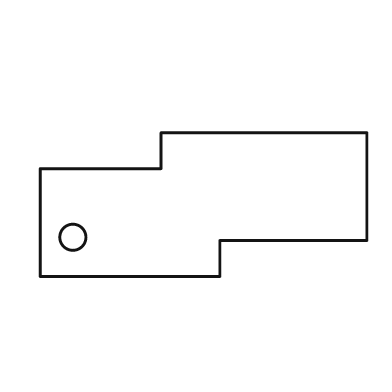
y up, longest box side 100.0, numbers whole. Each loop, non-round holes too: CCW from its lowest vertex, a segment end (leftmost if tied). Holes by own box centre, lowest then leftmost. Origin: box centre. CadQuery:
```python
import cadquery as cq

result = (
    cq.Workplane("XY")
    .moveTo(-50.0, -22.0)
    .lineTo(5.0, -22.0)
    .lineTo(5.0, -11.0)
    .lineTo(50.0, -11.0)
    .lineTo(50.0, 22.0)
    .lineTo(-13.0, 22.0)
    .lineTo(-13.0, 11.0)
    .lineTo(-50.0, 11.0)
    .close()
    .moveTo(-40.0, -10.0)
    .circle(4.0)
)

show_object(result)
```